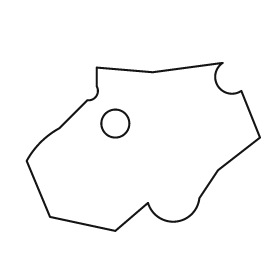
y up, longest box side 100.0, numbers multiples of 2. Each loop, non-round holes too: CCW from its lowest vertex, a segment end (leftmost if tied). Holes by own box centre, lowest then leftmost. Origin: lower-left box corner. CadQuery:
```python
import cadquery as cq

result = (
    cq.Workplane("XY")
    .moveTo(38.0, 0.0)
    .lineTo(52.0, 12.0)
    .threePointArc((64.0, 4.0), (74.0, 14.0))
    .lineTo(82.0, 26.0)
    .lineTo(100.0, 40.0)
    .lineTo(92.0, 60.0)
    .threePointArc((82.0, 62.0), (84.0, 72.0))
    .lineTo(54.0, 68.0)
    .lineTo(30.0, 70.0)
    .lineTo(30.0, 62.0)
    .threePointArc((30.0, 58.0), (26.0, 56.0))
    .lineTo(14.0, 44.0)
    .threePointArc((6.0, 38.0), (0.0, 30.0))
    .lineTo(10.0, 6.0)
    .close()
    .moveTo(38.0, 46.0)
    .circle(6.0)
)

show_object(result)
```